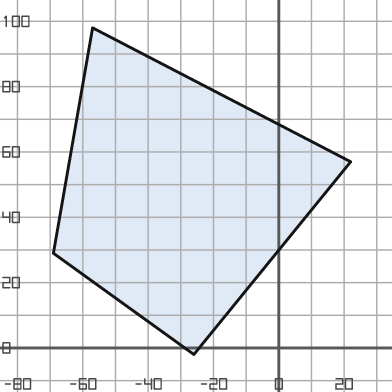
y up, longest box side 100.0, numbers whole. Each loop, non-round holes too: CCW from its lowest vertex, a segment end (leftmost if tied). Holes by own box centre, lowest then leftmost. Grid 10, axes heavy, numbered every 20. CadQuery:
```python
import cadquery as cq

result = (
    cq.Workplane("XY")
    .moveTo(-26.0, -2.0)
    .lineTo(22.0, 57.0)
    .lineTo(-57.0, 98.0)
    .lineTo(-69.0, 29.0)
    .close()
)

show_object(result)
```